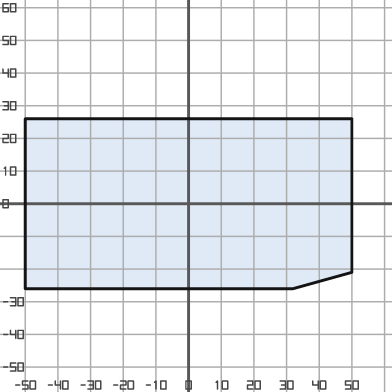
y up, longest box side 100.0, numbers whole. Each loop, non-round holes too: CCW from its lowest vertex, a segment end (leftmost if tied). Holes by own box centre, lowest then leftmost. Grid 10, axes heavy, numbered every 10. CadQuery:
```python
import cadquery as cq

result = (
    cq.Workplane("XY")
    .moveTo(-50.0, -26.0)
    .lineTo(32.0, -26.0)
    .lineTo(50.0, -21.0)
    .lineTo(50.0, 26.0)
    .lineTo(-50.0, 26.0)
    .close()
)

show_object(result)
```